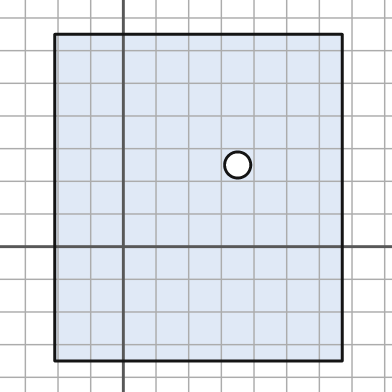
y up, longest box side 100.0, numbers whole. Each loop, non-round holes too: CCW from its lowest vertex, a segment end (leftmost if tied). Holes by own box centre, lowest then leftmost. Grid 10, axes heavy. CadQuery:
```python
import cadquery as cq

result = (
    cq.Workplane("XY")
    .moveTo(-21.0, -35.0)
    .lineTo(67.0, -35.0)
    .lineTo(67.0, 65.0)
    .lineTo(-21.0, 65.0)
    .close()
    .moveTo(35.0, 25.0)
    .circle(4.0)
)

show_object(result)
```